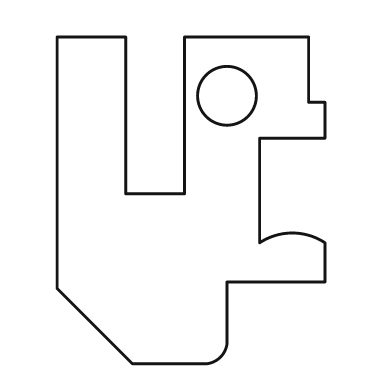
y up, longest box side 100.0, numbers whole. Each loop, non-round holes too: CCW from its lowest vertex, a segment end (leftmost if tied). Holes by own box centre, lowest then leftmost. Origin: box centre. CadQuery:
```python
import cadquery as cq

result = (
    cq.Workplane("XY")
    .moveTo(-18.0, -50.0)
    .lineTo(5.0, -50.0)
    .threePointArc((9.0, -48.0), (11.0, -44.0))
    .lineTo(11.0, -25.0)
    .lineTo(41.0, -25.0)
    .lineTo(41.0, -13.0)
    .threePointArc((31.0, -10.0), (21.0, -13.0))
    .lineTo(21.0, 19.0)
    .lineTo(41.0, 19.0)
    .lineTo(41.0, 30.0)
    .lineTo(36.0, 30.0)
    .lineTo(36.0, 50.0)
    .lineTo(-2.0, 50.0)
    .lineTo(-2.0, 2.0)
    .lineTo(-20.0, 2.0)
    .lineTo(-20.0, 50.0)
    .lineTo(-41.0, 50.0)
    .lineTo(-41.0, -27.0)
    .close()
    .moveTo(11.0, 32.0)
    .circle(9.0)
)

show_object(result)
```